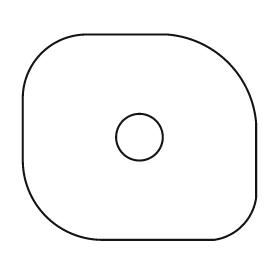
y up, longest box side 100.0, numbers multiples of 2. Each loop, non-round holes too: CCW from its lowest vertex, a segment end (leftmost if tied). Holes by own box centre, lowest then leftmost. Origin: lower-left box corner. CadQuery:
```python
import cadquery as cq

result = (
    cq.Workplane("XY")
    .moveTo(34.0, 0.0)
    .lineTo(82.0, 0.0)
    .threePointArc((94.0, 6.0), (100.0, 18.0))
    .lineTo(100.0, 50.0)
    .threePointArc((88.0, 76.0), (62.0, 88.0))
    .lineTo(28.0, 88.0)
    .threePointArc((8.0, 80.0), (0.0, 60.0))
    .lineTo(0.0, 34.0)
    .threePointArc((10.0, 10.0), (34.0, 0.0))
    .close()
    .moveTo(50.0, 44.0)
    .circle(10.0)
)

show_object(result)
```